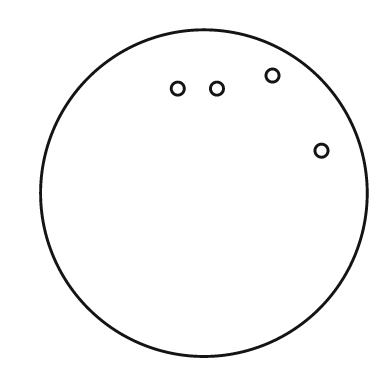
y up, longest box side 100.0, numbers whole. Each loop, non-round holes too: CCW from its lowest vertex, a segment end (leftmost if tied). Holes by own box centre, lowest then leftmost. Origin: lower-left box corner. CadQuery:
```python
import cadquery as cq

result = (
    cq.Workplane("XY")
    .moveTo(50.0, 50.0)
    .circle(50.0)
    .moveTo(86.0, 63.0)
    .circle(2.0)
    .moveTo(42.0, 82.0)
    .circle(2.0)
    .moveTo(54.0, 82.0)
    .circle(2.0)
    .moveTo(71.0, 86.0)
    .circle(2.0)
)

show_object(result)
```